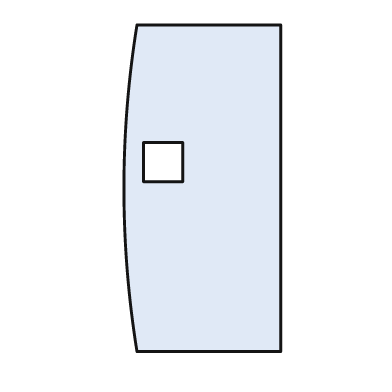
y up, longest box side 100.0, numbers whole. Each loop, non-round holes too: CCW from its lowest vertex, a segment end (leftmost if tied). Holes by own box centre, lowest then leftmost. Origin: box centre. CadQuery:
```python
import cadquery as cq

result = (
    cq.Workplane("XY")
    .moveTo(-20.0, -50.0)
    .lineTo(24.0, -50.0)
    .lineTo(24.0, 50.0)
    .lineTo(-20.0, 50.0)
    .threePointArc((-24.0, 0.0), (-20.0, -50.0))
    .close()
    .moveTo(-18.0, 2.0)
    .lineTo(-6.0, 2.0)
    .lineTo(-6.0, 14.0)
    .lineTo(-18.0, 14.0)
    .close()
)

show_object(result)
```